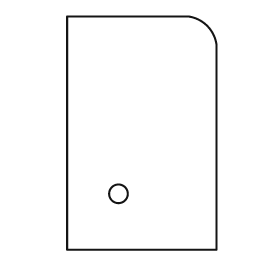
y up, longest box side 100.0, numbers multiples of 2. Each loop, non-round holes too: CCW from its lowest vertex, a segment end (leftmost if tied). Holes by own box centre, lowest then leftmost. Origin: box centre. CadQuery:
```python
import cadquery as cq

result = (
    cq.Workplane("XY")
    .moveTo(-32.0, -50.0)
    .lineTo(32.0, -50.0)
    .lineTo(32.0, 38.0)
    .threePointArc((28.0, 46.0), (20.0, 50.0))
    .lineTo(-32.0, 50.0)
    .close()
    .moveTo(-10.0, -26.0)
    .circle(4.0)
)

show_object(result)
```